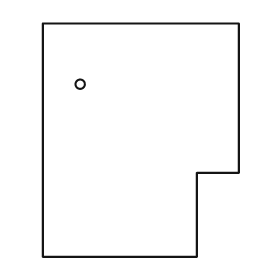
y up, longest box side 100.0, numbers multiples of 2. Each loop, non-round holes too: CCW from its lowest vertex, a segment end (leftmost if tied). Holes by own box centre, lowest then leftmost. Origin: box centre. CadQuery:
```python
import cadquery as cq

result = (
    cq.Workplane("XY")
    .moveTo(-42.0, -50.0)
    .lineTo(24.0, -50.0)
    .lineTo(24.0, -14.0)
    .lineTo(42.0, -14.0)
    .lineTo(42.0, 50.0)
    .lineTo(-42.0, 50.0)
    .close()
    .moveTo(-26.0, 24.0)
    .circle(2.0)
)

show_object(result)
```